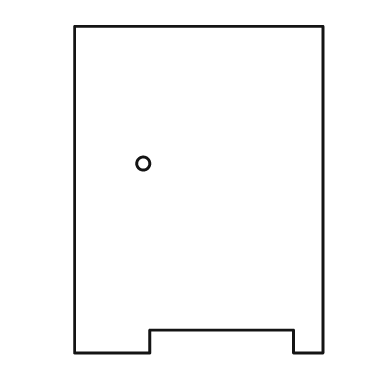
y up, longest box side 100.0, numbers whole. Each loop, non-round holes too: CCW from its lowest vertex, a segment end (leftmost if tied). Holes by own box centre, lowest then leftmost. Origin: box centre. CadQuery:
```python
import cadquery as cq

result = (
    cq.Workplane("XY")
    .moveTo(-38.0, -50.0)
    .lineTo(-15.0, -50.0)
    .lineTo(-15.0, -43.0)
    .lineTo(29.0, -43.0)
    .lineTo(29.0, -50.0)
    .lineTo(38.0, -50.0)
    .lineTo(38.0, 50.0)
    .lineTo(-38.0, 50.0)
    .close()
    .moveTo(-17.0, 8.0)
    .circle(2.0)
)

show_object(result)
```